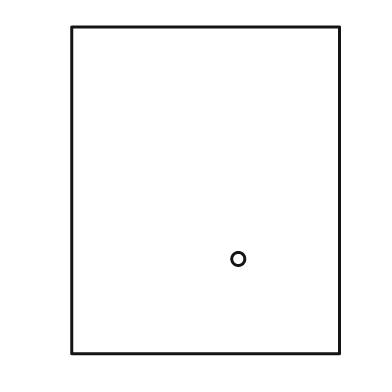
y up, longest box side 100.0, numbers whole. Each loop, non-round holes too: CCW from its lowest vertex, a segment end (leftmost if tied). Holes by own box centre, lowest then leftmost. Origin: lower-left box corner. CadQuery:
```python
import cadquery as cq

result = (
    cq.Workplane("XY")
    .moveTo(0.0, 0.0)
    .lineTo(82.0, 0.0)
    .lineTo(82.0, 100.0)
    .lineTo(0.0, 100.0)
    .close()
    .moveTo(51.0, 29.0)
    .circle(2.0)
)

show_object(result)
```